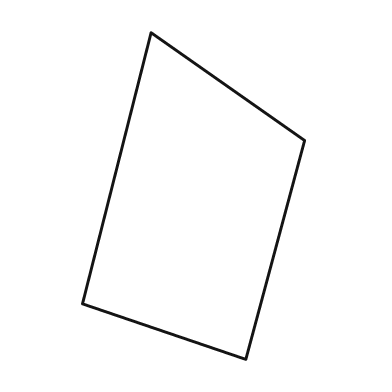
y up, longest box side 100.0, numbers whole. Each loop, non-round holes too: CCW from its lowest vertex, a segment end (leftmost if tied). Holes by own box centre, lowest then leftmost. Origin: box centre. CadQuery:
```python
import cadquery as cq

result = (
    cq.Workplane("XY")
    .moveTo(16.0, -50.0)
    .lineTo(34.0, 17.0)
    .lineTo(-13.0, 50.0)
    .lineTo(-34.0, -33.0)
    .close()
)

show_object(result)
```